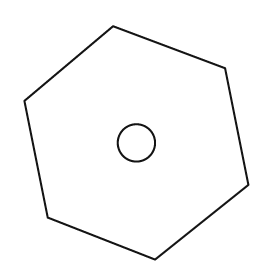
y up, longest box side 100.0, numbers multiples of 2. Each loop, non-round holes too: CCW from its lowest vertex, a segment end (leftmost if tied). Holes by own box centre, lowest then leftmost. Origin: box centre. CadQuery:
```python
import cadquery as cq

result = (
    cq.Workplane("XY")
    .moveTo(8.0, -50.0)
    .lineTo(48.0, -18.0)
    .lineTo(38.0, 32.0)
    .lineTo(-10.0, 50.0)
    .lineTo(-48.0, 18.0)
    .lineTo(-38.0, -32.0)
    .close()
    .moveTo(0.0, 0.0)
    .circle(8.0)
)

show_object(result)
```